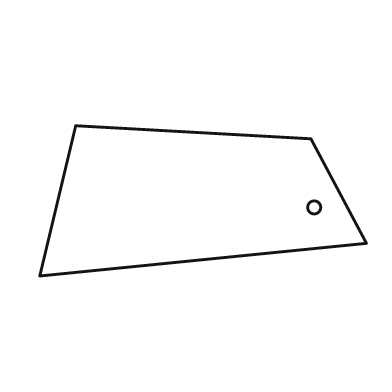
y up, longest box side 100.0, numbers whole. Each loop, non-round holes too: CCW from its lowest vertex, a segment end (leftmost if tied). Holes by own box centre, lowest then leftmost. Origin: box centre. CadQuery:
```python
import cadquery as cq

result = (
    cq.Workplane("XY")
    .moveTo(-50.0, -23.0)
    .lineTo(50.0, -13.0)
    .lineTo(33.0, 19.0)
    .lineTo(-39.0, 23.0)
    .close()
    .moveTo(34.0, -2.0)
    .circle(2.0)
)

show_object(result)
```